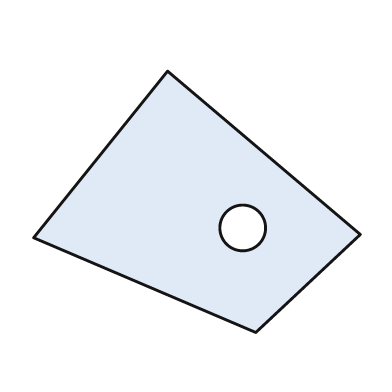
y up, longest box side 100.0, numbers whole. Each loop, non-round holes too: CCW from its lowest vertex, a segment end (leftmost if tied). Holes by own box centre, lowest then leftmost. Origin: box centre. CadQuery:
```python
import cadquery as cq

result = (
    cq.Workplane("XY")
    .moveTo(18.0, -40.0)
    .lineTo(50.0, -10.0)
    .lineTo(-9.0, 40.0)
    .lineTo(-50.0, -11.0)
    .close()
    .moveTo(14.0, -8.0)
    .circle(7.0)
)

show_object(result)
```